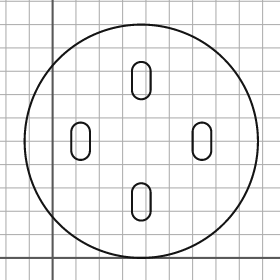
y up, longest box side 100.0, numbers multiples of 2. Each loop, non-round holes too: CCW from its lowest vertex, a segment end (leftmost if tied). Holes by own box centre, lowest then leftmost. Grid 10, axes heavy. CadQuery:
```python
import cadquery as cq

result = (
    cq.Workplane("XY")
    .moveTo(38.0, 50.0)
    .circle(50.0)
    .moveTo(34.0, 20.0)
    .threePointArc((38.0, 16.0), (42.0, 20.0))
    .lineTo(42.0, 28.0)
    .threePointArc((38.0, 32.0), (34.0, 28.0))
    .close()
    .moveTo(8.0, 46.0)
    .threePointArc((12.0, 42.0), (16.0, 46.0))
    .lineTo(16.0, 54.0)
    .threePointArc((12.0, 58.0), (8.0, 54.0))
    .close()
    .moveTo(60.0, 46.0)
    .threePointArc((64.0, 42.0), (68.0, 46.0))
    .lineTo(68.0, 54.0)
    .threePointArc((64.0, 58.0), (60.0, 54.0))
    .close()
    .moveTo(34.0, 72.0)
    .threePointArc((38.0, 68.0), (42.0, 72.0))
    .lineTo(42.0, 80.0)
    .threePointArc((38.0, 84.0), (34.0, 80.0))
    .close()
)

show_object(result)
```